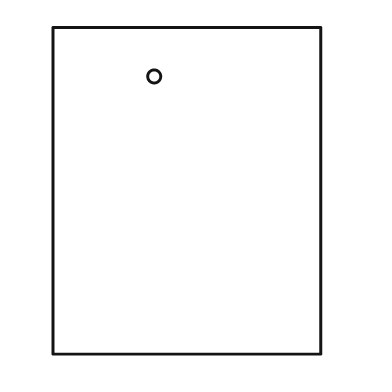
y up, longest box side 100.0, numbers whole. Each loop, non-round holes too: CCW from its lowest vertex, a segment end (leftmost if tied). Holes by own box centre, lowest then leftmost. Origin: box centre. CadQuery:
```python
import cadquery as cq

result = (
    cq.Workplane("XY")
    .moveTo(-41.0, -50.0)
    .lineTo(41.0, -50.0)
    .lineTo(41.0, 50.0)
    .lineTo(-41.0, 50.0)
    .close()
    .moveTo(-10.0, 35.0)
    .circle(2.0)
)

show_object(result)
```